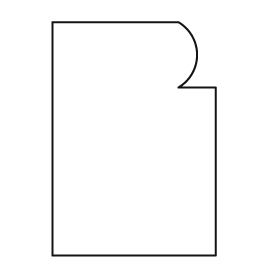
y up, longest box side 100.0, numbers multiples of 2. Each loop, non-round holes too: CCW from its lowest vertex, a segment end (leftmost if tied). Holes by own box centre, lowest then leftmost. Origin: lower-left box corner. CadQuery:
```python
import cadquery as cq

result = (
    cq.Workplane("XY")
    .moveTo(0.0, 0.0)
    .lineTo(70.0, 0.0)
    .lineTo(70.0, 72.0)
    .lineTo(54.0, 72.0)
    .threePointArc((62.0, 86.0), (54.0, 100.0))
    .lineTo(0.0, 100.0)
    .close()
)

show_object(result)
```